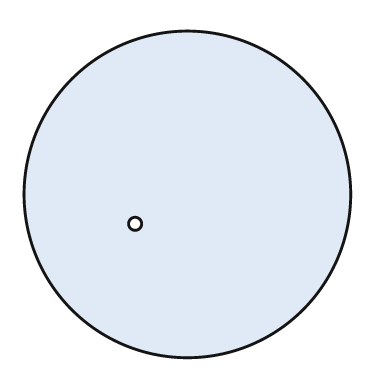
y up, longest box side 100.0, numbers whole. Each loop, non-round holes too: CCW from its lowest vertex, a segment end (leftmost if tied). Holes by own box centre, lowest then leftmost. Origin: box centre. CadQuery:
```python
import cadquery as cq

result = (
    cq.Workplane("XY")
    .moveTo(0.0, 0.0)
    .circle(50.0)
    .moveTo(-16.0, -9.0)
    .circle(2.0)
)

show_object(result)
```